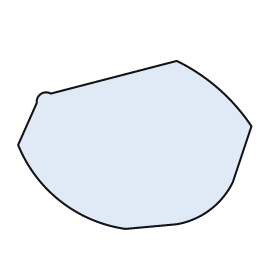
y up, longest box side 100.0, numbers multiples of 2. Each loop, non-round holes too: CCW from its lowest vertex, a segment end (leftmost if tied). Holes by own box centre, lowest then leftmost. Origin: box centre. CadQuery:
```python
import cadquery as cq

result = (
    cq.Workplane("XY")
    .moveTo(-4.0, -36.0)
    .lineTo(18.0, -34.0)
    .threePointArc((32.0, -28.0), (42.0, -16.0))
    .lineTo(50.0, 8.0)
    .threePointArc((36.0, 24.0), (18.0, 36.0))
    .lineTo(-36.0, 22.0)
    .threePointArc((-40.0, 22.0), (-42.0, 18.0))
    .lineTo(-50.0, 0.0)
    .threePointArc((-32.0, -24.0), (-4.0, -36.0))
    .close()
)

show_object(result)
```